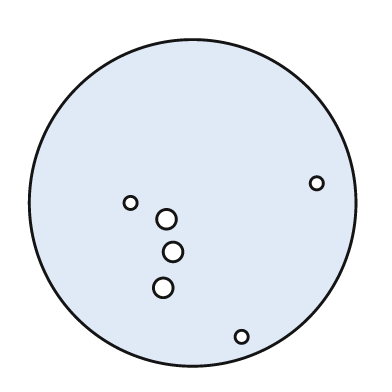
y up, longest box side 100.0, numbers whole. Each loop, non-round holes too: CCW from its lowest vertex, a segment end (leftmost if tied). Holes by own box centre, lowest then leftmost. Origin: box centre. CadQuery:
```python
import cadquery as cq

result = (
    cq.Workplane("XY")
    .moveTo(0.0, 0.0)
    .circle(50.0)
    .moveTo(15.0, -41.0)
    .circle(2.0)
    .moveTo(-9.0, -26.0)
    .circle(3.0)
    .moveTo(-6.0, -15.0)
    .circle(3.0)
    .moveTo(-8.0, -5.0)
    .circle(3.0)
    .moveTo(-19.0, 0.0)
    .circle(2.0)
    .moveTo(38.0, 6.0)
    .circle(2.0)
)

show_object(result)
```